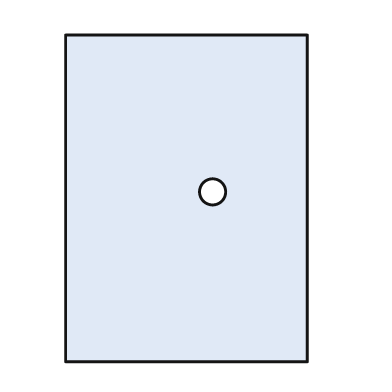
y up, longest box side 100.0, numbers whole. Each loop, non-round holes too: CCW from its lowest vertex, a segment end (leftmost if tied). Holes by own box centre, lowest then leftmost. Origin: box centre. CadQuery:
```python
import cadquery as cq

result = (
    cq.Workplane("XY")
    .moveTo(-37.0, -50.0)
    .lineTo(37.0, -50.0)
    .lineTo(37.0, 50.0)
    .lineTo(-37.0, 50.0)
    .close()
    .moveTo(8.0, 2.0)
    .circle(4.0)
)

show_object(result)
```